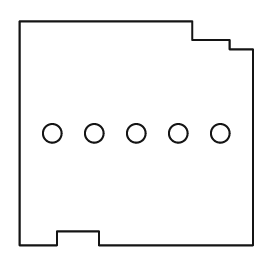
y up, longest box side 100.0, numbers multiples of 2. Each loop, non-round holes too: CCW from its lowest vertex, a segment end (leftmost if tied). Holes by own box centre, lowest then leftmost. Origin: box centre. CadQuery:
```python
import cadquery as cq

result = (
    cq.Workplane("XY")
    .moveTo(-50.0, -48.0)
    .lineTo(-34.0, -48.0)
    .lineTo(-34.0, -42.0)
    .lineTo(-16.0, -42.0)
    .lineTo(-16.0, -48.0)
    .lineTo(50.0, -48.0)
    .lineTo(50.0, 36.0)
    .lineTo(40.0, 36.0)
    .lineTo(40.0, 40.0)
    .lineTo(24.0, 40.0)
    .lineTo(24.0, 48.0)
    .lineTo(-50.0, 48.0)
    .close()
    .moveTo(-36.0, 0.0)
    .circle(4.0)
    .moveTo(-18.0, 0.0)
    .circle(4.0)
    .moveTo(0.0, 0.0)
    .circle(4.0)
    .moveTo(18.0, 0.0)
    .circle(4.0)
    .moveTo(36.0, 0.0)
    .circle(4.0)
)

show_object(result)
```